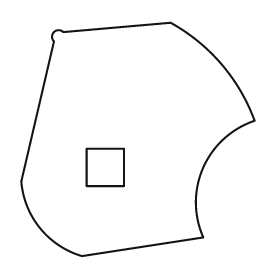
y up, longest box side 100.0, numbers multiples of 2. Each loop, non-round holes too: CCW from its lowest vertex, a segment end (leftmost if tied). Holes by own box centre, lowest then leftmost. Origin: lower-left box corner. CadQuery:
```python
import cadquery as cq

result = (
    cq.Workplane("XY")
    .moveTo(26.0, 0.0)
    .lineTo(78.0, 8.0)
    .threePointArc((78.0, 38.0), (100.0, 58.0))
    .threePointArc((86.0, 82.0), (64.0, 100.0))
    .lineTo(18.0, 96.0)
    .threePointArc((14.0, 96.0), (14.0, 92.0))
    .lineTo(0.0, 32.0)
    .threePointArc((8.0, 12.0), (26.0, 0.0))
    .close()
    .moveTo(28.0, 30.0)
    .lineTo(44.0, 30.0)
    .lineTo(44.0, 46.0)
    .lineTo(28.0, 46.0)
    .close()
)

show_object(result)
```